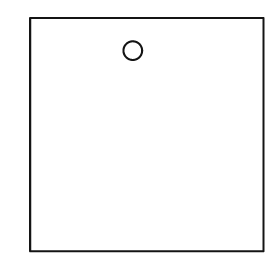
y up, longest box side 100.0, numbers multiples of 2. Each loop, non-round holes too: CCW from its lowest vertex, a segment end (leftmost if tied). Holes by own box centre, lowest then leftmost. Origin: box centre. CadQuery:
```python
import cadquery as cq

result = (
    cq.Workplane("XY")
    .moveTo(-50.0, -50.0)
    .lineTo(50.0, -50.0)
    .lineTo(50.0, 50.0)
    .lineTo(-50.0, 50.0)
    .close()
    .moveTo(-6.0, 36.0)
    .circle(4.0)
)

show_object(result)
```